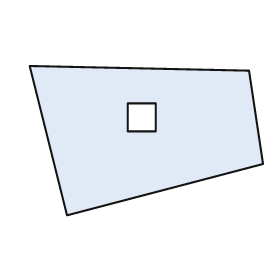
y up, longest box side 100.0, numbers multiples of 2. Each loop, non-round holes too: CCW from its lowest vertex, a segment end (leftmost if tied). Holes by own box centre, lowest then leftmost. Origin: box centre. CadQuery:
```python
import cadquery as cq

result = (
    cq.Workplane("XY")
    .moveTo(-34.0, -32.0)
    .lineTo(50.0, -10.0)
    .lineTo(44.0, 30.0)
    .lineTo(-50.0, 32.0)
    .close()
    .moveTo(-8.0, 4.0)
    .lineTo(4.0, 4.0)
    .lineTo(4.0, 16.0)
    .lineTo(-8.0, 16.0)
    .close()
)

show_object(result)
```